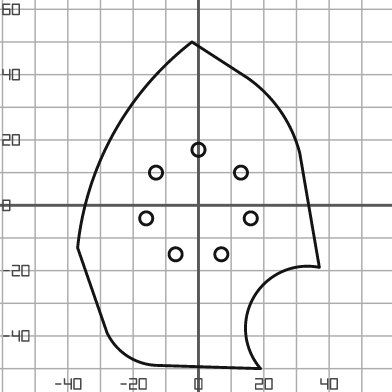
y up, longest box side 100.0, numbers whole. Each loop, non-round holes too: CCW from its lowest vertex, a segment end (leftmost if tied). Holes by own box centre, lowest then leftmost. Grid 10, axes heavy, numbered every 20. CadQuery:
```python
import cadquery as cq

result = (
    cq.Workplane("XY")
    .moveTo(19.0, -50.0)
    .threePointArc((17.0, -28.0), (37.0, -19.0))
    .lineTo(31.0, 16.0)
    .threePointArc((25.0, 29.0), (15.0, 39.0))
    .lineTo(-2.0, 50.0)
    .threePointArc((-26.0, 22.0), (-37.0, -13.0))
    .lineTo(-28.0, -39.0)
    .threePointArc((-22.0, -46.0), (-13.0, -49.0))
    .close()
    .moveTo(-7.0, -15.0)
    .circle(2.0)
    .moveTo(7.0, -15.0)
    .circle(2.0)
    .moveTo(-16.0, -4.0)
    .circle(2.0)
    .moveTo(16.0, -4.0)
    .circle(2.0)
    .moveTo(-13.0, 10.0)
    .circle(2.0)
    .moveTo(13.0, 10.0)
    .circle(2.0)
    .moveTo(0.0, 17.0)
    .circle(2.0)
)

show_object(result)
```